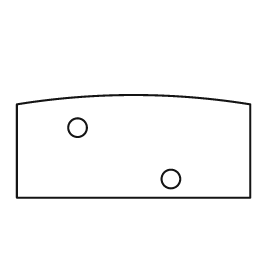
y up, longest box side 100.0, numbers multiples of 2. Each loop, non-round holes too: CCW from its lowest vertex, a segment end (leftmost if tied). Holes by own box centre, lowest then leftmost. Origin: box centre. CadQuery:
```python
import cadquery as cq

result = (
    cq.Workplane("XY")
    .moveTo(-50.0, -22.0)
    .lineTo(50.0, -22.0)
    .lineTo(50.0, 18.0)
    .threePointArc((0.0, 22.0), (-50.0, 18.0))
    .close()
    .moveTo(16.0, -14.0)
    .circle(4.0)
    .moveTo(-24.0, 8.0)
    .circle(4.0)
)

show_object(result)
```